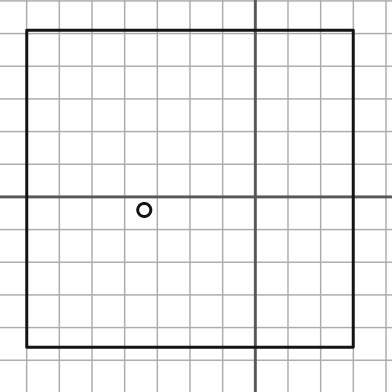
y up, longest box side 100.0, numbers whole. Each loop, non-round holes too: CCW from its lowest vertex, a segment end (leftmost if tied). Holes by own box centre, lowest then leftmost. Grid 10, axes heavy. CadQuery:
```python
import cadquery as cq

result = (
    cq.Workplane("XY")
    .moveTo(-70.0, -46.0)
    .lineTo(30.0, -46.0)
    .lineTo(30.0, 51.0)
    .lineTo(-70.0, 51.0)
    .close()
    .moveTo(-34.0, -4.0)
    .circle(2.0)
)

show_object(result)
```